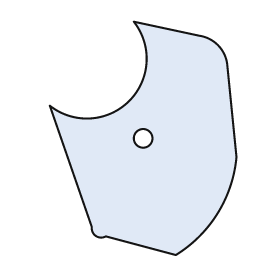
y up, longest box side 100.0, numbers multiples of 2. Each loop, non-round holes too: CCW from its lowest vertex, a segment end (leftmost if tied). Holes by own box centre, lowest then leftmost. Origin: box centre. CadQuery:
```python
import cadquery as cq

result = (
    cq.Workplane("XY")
    .moveTo(14.0, -50.0)
    .threePointArc((32.0, -32.0), (40.0, -8.0))
    .lineTo(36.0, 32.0)
    .threePointArc((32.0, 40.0), (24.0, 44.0))
    .lineTo(-4.0, 50.0)
    .threePointArc((-6.0, 16.0), (-40.0, 14.0))
    .lineTo(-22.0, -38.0)
    .threePointArc((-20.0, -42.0), (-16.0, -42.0))
    .close()
    .moveTo(0.0, 0.0)
    .circle(4.0)
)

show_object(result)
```